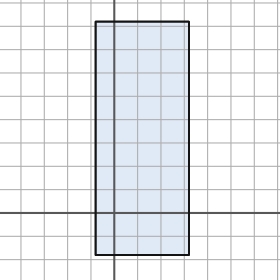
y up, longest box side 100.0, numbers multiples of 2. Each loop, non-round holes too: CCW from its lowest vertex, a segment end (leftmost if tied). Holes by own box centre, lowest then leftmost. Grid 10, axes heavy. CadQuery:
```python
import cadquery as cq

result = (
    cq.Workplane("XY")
    .moveTo(-8.0, -18.0)
    .lineTo(32.0, -18.0)
    .lineTo(32.0, 82.0)
    .lineTo(-8.0, 82.0)
    .close()
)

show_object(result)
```